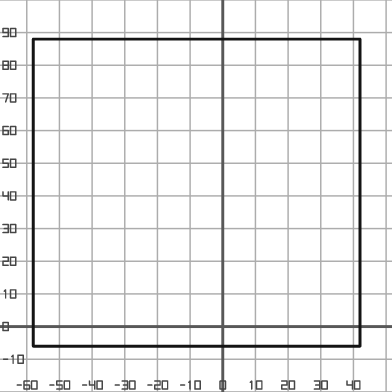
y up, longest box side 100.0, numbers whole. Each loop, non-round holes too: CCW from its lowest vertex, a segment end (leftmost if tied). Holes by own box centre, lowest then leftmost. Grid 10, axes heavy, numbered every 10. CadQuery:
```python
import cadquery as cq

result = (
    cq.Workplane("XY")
    .moveTo(-58.0, -6.0)
    .lineTo(42.0, -6.0)
    .lineTo(42.0, 88.0)
    .lineTo(-58.0, 88.0)
    .close()
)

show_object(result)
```